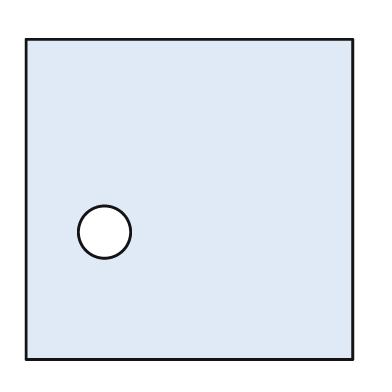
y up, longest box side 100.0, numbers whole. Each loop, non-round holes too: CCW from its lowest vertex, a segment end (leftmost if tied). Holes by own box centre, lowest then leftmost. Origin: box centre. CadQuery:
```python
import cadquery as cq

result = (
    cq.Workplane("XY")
    .moveTo(-50.0, -49.0)
    .lineTo(50.0, -49.0)
    .lineTo(50.0, 49.0)
    .lineTo(-50.0, 49.0)
    .close()
    .moveTo(-26.0, -10.0)
    .circle(8.0)
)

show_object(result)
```